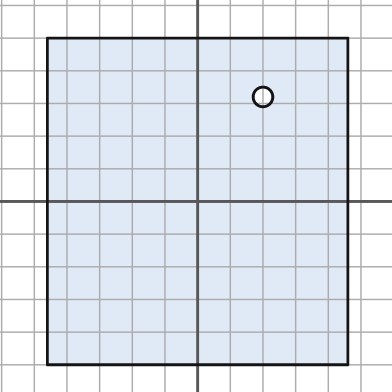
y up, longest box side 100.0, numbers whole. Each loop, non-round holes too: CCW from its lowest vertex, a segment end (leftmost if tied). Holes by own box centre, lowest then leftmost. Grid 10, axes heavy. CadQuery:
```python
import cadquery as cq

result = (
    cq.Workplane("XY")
    .moveTo(-46.0, -50.0)
    .lineTo(46.0, -50.0)
    .lineTo(46.0, 50.0)
    .lineTo(-46.0, 50.0)
    .close()
    .moveTo(20.0, 32.0)
    .circle(3.0)
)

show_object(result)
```